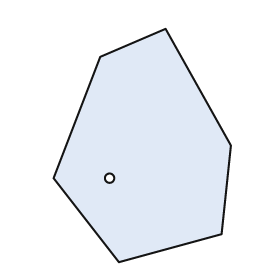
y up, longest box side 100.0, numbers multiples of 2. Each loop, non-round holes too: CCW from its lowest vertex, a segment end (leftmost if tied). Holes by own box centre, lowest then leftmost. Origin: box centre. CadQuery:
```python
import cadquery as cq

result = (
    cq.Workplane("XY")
    .moveTo(-10.0, -50.0)
    .lineTo(34.0, -38.0)
    .lineTo(38.0, 0.0)
    .lineTo(10.0, 50.0)
    .lineTo(-18.0, 38.0)
    .lineTo(-38.0, -14.0)
    .close()
    .moveTo(-14.0, -14.0)
    .circle(2.0)
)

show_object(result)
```